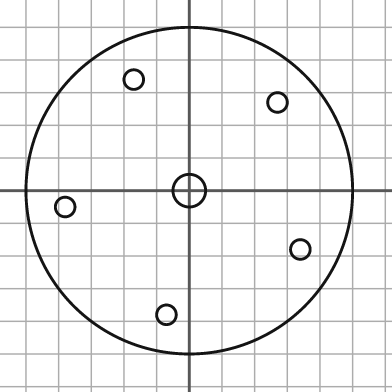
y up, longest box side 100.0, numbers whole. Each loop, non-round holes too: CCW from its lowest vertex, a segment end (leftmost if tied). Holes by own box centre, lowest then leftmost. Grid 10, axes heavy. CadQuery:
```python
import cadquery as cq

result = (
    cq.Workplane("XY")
    .moveTo(0.0, 0.0)
    .circle(50.0)
    .moveTo(-7.0, -38.0)
    .circle(3.0)
    .moveTo(34.0, -18.0)
    .circle(3.0)
    .moveTo(-38.0, -5.0)
    .circle(3.0)
    .moveTo(0.0, 0.0)
    .circle(5.0)
    .moveTo(27.0, 27.0)
    .circle(3.0)
    .moveTo(-17.0, 34.0)
    .circle(3.0)
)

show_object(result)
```